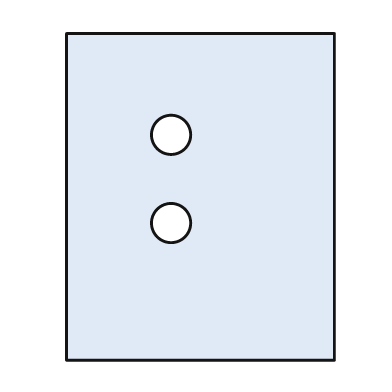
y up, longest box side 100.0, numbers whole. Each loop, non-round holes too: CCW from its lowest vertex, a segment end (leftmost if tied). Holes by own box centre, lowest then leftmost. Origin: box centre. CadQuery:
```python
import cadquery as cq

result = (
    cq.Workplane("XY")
    .moveTo(-41.0, -50.0)
    .lineTo(41.0, -50.0)
    .lineTo(41.0, 50.0)
    .lineTo(-41.0, 50.0)
    .close()
    .moveTo(-9.0, -8.0)
    .circle(6.0)
    .moveTo(-9.0, 19.0)
    .circle(6.0)
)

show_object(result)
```